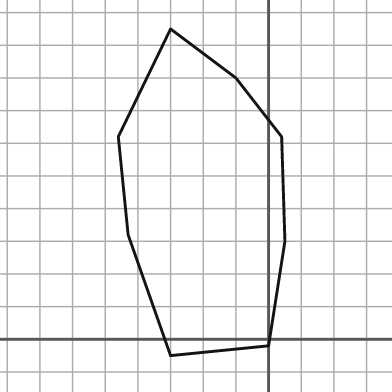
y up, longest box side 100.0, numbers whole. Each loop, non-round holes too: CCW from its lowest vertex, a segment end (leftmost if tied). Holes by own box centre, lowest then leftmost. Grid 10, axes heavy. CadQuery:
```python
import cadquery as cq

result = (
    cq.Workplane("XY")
    .moveTo(-30.0, -5.0)
    .lineTo(0.0, -2.0)
    .lineTo(5.0, 30.0)
    .lineTo(4.0, 62.0)
    .lineTo(-10.0, 80.0)
    .lineTo(-30.0, 95.0)
    .lineTo(-46.0, 62.0)
    .lineTo(-43.0, 32.0)
    .close()
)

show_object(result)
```